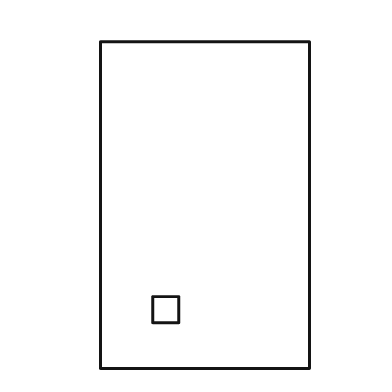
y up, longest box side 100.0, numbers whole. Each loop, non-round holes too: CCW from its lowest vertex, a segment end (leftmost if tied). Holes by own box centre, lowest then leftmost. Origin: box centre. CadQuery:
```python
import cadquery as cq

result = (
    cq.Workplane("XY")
    .moveTo(-32.0, -50.0)
    .lineTo(32.0, -50.0)
    .lineTo(32.0, 50.0)
    .lineTo(-32.0, 50.0)
    .close()
    .moveTo(-16.0, -36.0)
    .lineTo(-8.0, -36.0)
    .lineTo(-8.0, -28.0)
    .lineTo(-16.0, -28.0)
    .close()
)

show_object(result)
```